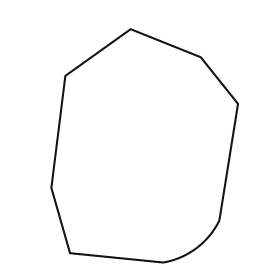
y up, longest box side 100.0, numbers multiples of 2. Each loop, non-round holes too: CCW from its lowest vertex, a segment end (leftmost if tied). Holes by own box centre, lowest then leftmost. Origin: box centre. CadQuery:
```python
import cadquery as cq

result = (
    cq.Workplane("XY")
    .moveTo(8.0, -50.0)
    .threePointArc((22.0, -44.0), (32.0, -32.0))
    .lineTo(40.0, 18.0)
    .lineTo(24.0, 38.0)
    .lineTo(-6.0, 50.0)
    .lineTo(-34.0, 30.0)
    .lineTo(-40.0, -18.0)
    .lineTo(-32.0, -46.0)
    .close()
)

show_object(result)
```